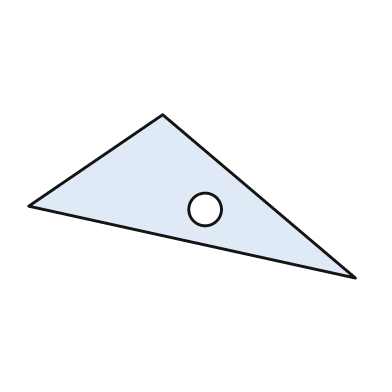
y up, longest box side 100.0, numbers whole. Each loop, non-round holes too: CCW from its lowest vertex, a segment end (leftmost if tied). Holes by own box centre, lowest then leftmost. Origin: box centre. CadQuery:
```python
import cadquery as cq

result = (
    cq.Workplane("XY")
    .moveTo(50.0, -25.0)
    .lineTo(-9.0, 25.0)
    .lineTo(-50.0, -3.0)
    .close()
    .moveTo(4.0, -4.0)
    .circle(5.0)
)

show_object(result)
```